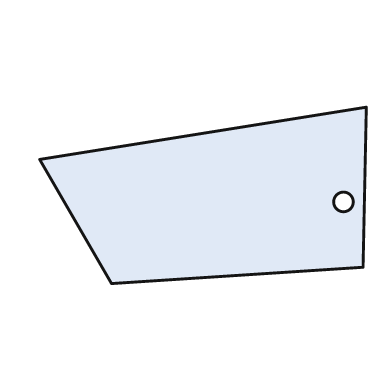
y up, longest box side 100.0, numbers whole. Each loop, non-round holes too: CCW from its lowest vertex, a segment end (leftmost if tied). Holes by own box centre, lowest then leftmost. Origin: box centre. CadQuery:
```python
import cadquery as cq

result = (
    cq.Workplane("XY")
    .moveTo(-28.0, -27.0)
    .lineTo(49.0, -22.0)
    .lineTo(50.0, 27.0)
    .lineTo(-50.0, 11.0)
    .close()
    .moveTo(43.0, -2.0)
    .circle(3.0)
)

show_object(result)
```